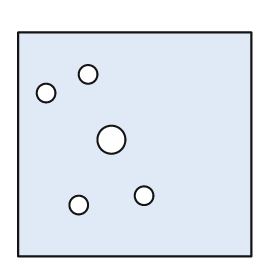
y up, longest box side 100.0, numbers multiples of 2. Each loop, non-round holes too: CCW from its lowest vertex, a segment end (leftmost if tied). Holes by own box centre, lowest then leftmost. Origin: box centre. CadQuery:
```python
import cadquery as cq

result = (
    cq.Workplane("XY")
    .moveTo(-50.0, -48.0)
    .lineTo(50.0, -48.0)
    .lineTo(50.0, 48.0)
    .lineTo(-50.0, 48.0)
    .close()
    .moveTo(-24.0, -26.0)
    .circle(4.0)
    .moveTo(4.0, -22.0)
    .circle(4.0)
    .moveTo(-10.0, 2.0)
    .circle(6.0)
    .moveTo(-38.0, 22.0)
    .circle(4.0)
    .moveTo(-20.0, 30.0)
    .circle(4.0)
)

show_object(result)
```